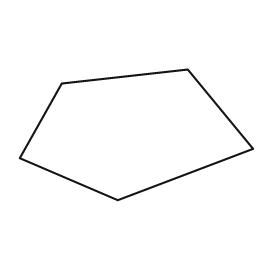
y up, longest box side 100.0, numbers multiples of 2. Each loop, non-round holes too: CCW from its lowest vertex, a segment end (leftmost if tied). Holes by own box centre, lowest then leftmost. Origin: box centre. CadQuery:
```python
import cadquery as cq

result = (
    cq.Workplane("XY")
    .moveTo(-8.0, -28.0)
    .lineTo(50.0, -6.0)
    .lineTo(22.0, 28.0)
    .lineTo(-32.0, 22.0)
    .lineTo(-50.0, -10.0)
    .close()
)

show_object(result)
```